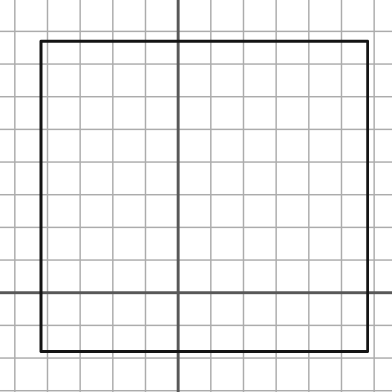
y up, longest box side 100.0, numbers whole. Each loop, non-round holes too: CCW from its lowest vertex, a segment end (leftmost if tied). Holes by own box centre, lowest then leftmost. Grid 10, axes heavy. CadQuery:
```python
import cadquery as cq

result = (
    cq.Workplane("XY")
    .moveTo(-42.0, -18.0)
    .lineTo(58.0, -18.0)
    .lineTo(58.0, 77.0)
    .lineTo(-42.0, 77.0)
    .close()
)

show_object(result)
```